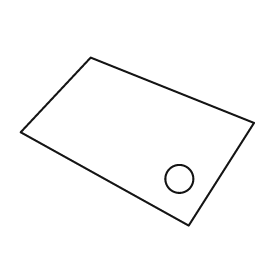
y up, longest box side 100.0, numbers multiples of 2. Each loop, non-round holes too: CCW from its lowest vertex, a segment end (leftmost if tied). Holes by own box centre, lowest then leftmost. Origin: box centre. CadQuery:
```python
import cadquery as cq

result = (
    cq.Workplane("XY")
    .moveTo(22.0, -36.0)
    .lineTo(50.0, 8.0)
    .lineTo(-20.0, 36.0)
    .lineTo(-50.0, 4.0)
    .close()
    .moveTo(18.0, -16.0)
    .circle(6.0)
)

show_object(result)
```